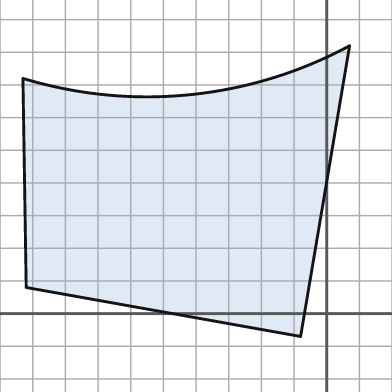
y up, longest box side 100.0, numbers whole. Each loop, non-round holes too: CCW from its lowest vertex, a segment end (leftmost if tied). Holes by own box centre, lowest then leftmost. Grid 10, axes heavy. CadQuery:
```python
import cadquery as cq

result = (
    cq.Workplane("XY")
    .moveTo(-8.0, -7.0)
    .lineTo(7.0, 82.0)
    .threePointArc((-42.0, 67.0), (-93.0, 72.0))
    .lineTo(-92.0, 8.0)
    .close()
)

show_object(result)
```